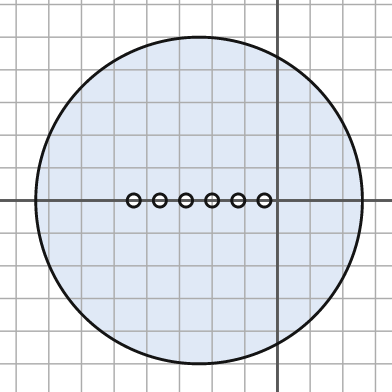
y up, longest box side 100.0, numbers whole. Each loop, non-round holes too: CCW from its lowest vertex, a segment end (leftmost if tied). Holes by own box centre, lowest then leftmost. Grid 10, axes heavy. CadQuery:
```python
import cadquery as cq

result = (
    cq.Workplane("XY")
    .moveTo(-24.0, 0.0)
    .circle(50.0)
    .moveTo(-44.0, 0.0)
    .circle(2.0)
    .moveTo(-36.0, 0.0)
    .circle(2.0)
    .moveTo(-28.0, 0.0)
    .circle(2.0)
    .moveTo(-20.0, 0.0)
    .circle(2.0)
    .moveTo(-12.0, 0.0)
    .circle(2.0)
    .moveTo(-4.0, 0.0)
    .circle(2.0)
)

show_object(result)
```